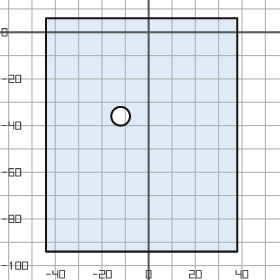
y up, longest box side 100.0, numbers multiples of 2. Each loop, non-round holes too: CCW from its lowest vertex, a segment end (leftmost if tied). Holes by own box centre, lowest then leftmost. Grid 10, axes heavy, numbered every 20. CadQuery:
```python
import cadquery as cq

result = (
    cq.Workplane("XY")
    .moveTo(-44.0, -94.0)
    .lineTo(38.0, -94.0)
    .lineTo(38.0, 6.0)
    .lineTo(-44.0, 6.0)
    .close()
    .moveTo(-12.0, -36.0)
    .circle(4.0)
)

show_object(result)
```